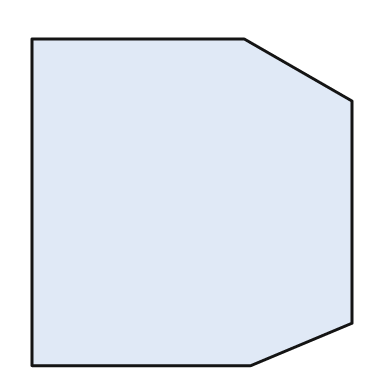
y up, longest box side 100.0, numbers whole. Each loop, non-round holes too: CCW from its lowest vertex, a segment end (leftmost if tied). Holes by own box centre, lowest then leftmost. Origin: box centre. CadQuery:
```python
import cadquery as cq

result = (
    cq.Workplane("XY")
    .moveTo(-49.0, -50.0)
    .lineTo(18.0, -50.0)
    .lineTo(49.0, -37.0)
    .lineTo(49.0, 31.0)
    .lineTo(16.0, 50.0)
    .lineTo(-49.0, 50.0)
    .close()
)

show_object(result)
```